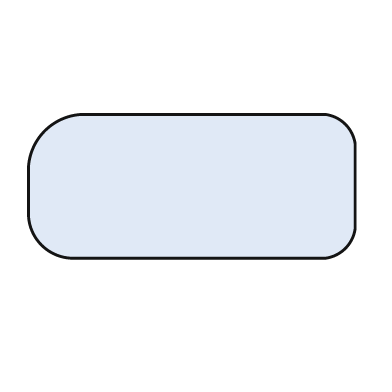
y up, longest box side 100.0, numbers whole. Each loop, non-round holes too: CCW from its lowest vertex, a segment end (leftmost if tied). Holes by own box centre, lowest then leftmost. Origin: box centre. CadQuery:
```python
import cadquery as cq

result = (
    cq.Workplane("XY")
    .moveTo(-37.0, -22.0)
    .lineTo(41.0, -22.0)
    .threePointArc((47.0, -19.0), (50.0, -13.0))
    .lineTo(50.0, 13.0)
    .threePointArc((47.0, 19.0), (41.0, 22.0))
    .lineTo(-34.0, 22.0)
    .threePointArc((-45.0, 17.0), (-50.0, 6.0))
    .lineTo(-50.0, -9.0)
    .threePointArc((-46.0, -18.0), (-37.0, -22.0))
    .close()
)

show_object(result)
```